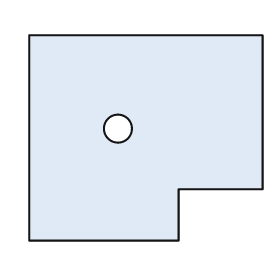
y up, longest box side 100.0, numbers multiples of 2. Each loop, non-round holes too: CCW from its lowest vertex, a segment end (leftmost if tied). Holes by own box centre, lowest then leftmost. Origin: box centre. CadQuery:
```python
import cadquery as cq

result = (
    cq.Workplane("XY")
    .moveTo(-50.0, -44.0)
    .lineTo(14.0, -44.0)
    .lineTo(14.0, -22.0)
    .lineTo(50.0, -22.0)
    .lineTo(50.0, 44.0)
    .lineTo(-50.0, 44.0)
    .close()
    .moveTo(-12.0, 4.0)
    .circle(6.0)
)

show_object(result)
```